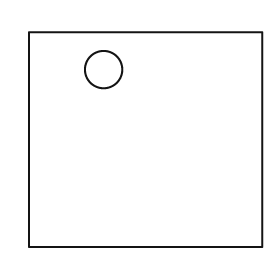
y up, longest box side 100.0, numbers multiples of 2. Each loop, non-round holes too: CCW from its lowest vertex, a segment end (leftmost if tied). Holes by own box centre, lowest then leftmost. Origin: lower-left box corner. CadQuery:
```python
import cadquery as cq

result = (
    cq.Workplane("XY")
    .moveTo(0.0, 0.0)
    .lineTo(100.0, 0.0)
    .lineTo(100.0, 92.0)
    .lineTo(0.0, 92.0)
    .close()
    .moveTo(32.0, 76.0)
    .circle(8.0)
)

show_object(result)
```